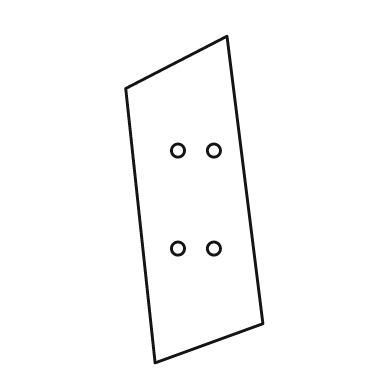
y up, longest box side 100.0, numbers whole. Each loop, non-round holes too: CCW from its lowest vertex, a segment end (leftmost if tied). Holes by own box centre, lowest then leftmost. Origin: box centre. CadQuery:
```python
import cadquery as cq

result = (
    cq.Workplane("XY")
    .moveTo(-12.0, -50.0)
    .lineTo(21.0, -38.0)
    .lineTo(10.0, 50.0)
    .lineTo(-21.0, 34.0)
    .close()
    .moveTo(-5.0, -15.0)
    .circle(2.0)
    .moveTo(6.0, -15.0)
    .circle(2.0)
    .moveTo(-5.0, 15.0)
    .circle(2.0)
    .moveTo(6.0, 15.0)
    .circle(2.0)
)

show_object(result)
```